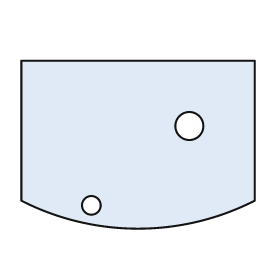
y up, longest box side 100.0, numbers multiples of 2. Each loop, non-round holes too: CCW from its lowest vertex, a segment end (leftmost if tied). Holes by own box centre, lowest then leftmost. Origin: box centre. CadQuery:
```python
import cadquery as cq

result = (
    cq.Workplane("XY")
    .moveTo(-50.0, -24.0)
    .threePointArc((0.0, -36.0), (50.0, -24.0))
    .lineTo(50.0, 36.0)
    .lineTo(-50.0, 36.0)
    .close()
    .moveTo(-20.0, -26.0)
    .circle(4.0)
    .moveTo(22.0, 8.0)
    .circle(6.0)
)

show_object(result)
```